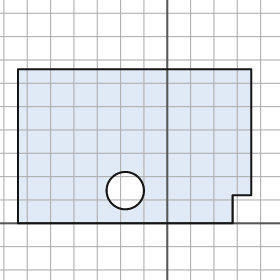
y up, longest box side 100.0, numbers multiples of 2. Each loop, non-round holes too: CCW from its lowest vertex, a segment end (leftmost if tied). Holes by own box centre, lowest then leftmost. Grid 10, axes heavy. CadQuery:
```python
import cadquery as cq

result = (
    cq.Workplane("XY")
    .moveTo(-64.0, 0.0)
    .lineTo(28.0, 0.0)
    .lineTo(28.0, 12.0)
    .lineTo(36.0, 12.0)
    .lineTo(36.0, 66.0)
    .lineTo(-64.0, 66.0)
    .close()
    .moveTo(-18.0, 14.0)
    .circle(8.0)
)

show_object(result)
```